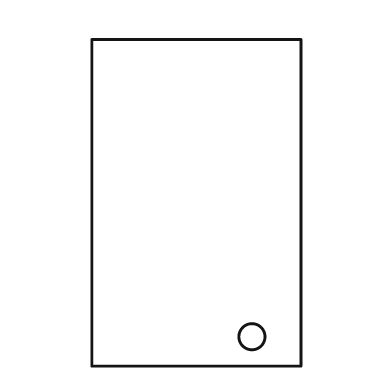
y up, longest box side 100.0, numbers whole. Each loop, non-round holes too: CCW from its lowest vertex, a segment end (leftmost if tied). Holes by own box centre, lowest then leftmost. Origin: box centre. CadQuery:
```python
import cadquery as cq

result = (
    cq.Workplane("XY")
    .moveTo(-32.0, -50.0)
    .lineTo(32.0, -50.0)
    .lineTo(32.0, 50.0)
    .lineTo(-32.0, 50.0)
    .close()
    .moveTo(17.0, -41.0)
    .circle(4.0)
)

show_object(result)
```